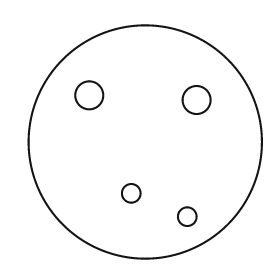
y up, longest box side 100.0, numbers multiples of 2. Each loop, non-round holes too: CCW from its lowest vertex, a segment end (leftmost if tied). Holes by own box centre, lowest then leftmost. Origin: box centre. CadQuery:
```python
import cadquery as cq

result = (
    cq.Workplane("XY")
    .moveTo(0.0, 0.0)
    .circle(50.0)
    .moveTo(18.0, -32.0)
    .circle(4.0)
    .moveTo(-6.0, -22.0)
    .circle(4.0)
    .moveTo(22.0, 18.0)
    .circle(6.0)
    .moveTo(-24.0, 20.0)
    .circle(6.0)
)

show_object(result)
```